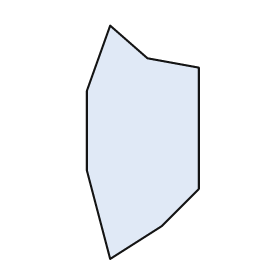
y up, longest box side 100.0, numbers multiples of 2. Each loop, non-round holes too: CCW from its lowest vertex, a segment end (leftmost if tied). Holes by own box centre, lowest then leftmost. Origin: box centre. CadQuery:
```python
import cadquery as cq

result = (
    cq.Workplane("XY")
    .moveTo(-14.0, -50.0)
    .lineTo(8.0, -36.0)
    .lineTo(24.0, -20.0)
    .lineTo(24.0, 32.0)
    .lineTo(2.0, 36.0)
    .lineTo(-14.0, 50.0)
    .lineTo(-24.0, 22.0)
    .lineTo(-24.0, -12.0)
    .close()
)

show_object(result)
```